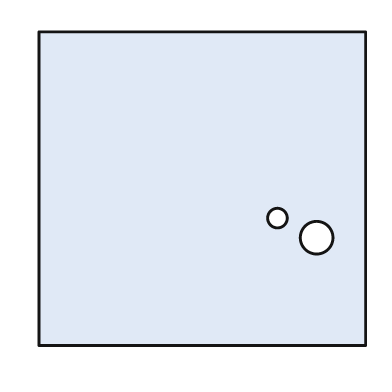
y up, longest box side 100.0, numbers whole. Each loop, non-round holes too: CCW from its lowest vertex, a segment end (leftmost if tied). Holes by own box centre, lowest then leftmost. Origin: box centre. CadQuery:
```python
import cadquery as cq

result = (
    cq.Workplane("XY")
    .moveTo(-50.0, -48.0)
    .lineTo(50.0, -48.0)
    .lineTo(50.0, 48.0)
    .lineTo(-50.0, 48.0)
    .close()
    .moveTo(35.0, -15.0)
    .circle(5.0)
    .moveTo(23.0, -9.0)
    .circle(3.0)
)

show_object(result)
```